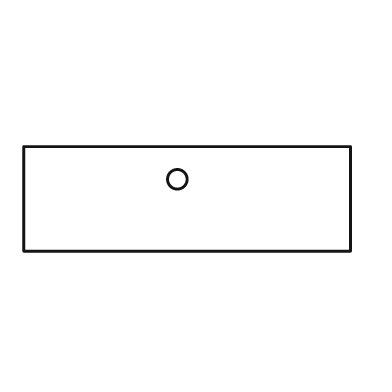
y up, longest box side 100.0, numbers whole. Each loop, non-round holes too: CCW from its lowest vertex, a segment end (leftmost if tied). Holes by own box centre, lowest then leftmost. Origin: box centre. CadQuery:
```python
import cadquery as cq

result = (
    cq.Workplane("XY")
    .moveTo(-50.0, -16.0)
    .lineTo(50.0, -16.0)
    .lineTo(50.0, 16.0)
    .lineTo(-50.0, 16.0)
    .close()
    .moveTo(-3.0, 6.0)
    .circle(3.0)
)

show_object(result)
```